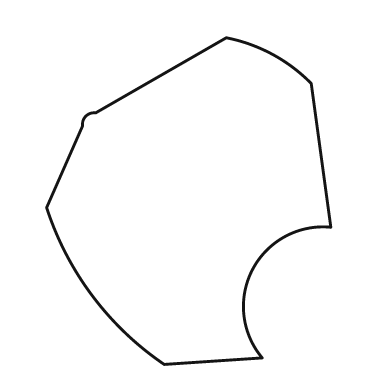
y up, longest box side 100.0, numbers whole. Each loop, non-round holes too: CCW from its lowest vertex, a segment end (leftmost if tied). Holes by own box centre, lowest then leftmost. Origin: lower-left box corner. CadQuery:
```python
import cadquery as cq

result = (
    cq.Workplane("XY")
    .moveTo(36.0, 0.0)
    .lineTo(66.0, 2.0)
    .threePointArc((63.0, 29.0), (87.0, 42.0))
    .lineTo(81.0, 86.0)
    .threePointArc((69.0, 95.0), (55.0, 100.0))
    .lineTo(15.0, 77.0)
    .threePointArc((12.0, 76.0), (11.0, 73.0))
    .lineTo(0.0, 48.0)
    .threePointArc((14.0, 21.0), (36.0, 0.0))
    .close()
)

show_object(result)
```